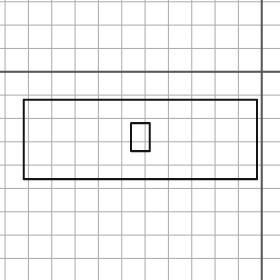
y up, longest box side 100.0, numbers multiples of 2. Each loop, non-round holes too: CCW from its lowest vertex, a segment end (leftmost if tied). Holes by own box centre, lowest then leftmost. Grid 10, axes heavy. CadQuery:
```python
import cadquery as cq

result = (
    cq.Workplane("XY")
    .moveTo(-102.0, -46.0)
    .lineTo(-2.0, -46.0)
    .lineTo(-2.0, -12.0)
    .lineTo(-102.0, -12.0)
    .close()
    .moveTo(-56.0, -34.0)
    .lineTo(-48.0, -34.0)
    .lineTo(-48.0, -22.0)
    .lineTo(-56.0, -22.0)
    .close()
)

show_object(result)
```